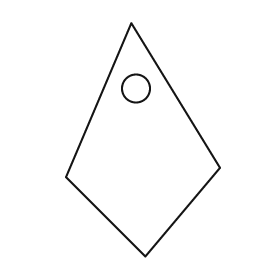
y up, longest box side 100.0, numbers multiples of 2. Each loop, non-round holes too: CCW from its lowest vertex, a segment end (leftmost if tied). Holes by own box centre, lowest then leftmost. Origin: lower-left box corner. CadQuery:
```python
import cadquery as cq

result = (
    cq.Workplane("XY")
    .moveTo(34.0, 0.0)
    .lineTo(66.0, 38.0)
    .lineTo(28.0, 100.0)
    .lineTo(0.0, 34.0)
    .close()
    .moveTo(30.0, 72.0)
    .circle(6.0)
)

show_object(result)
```